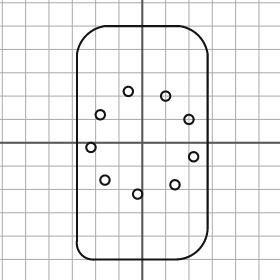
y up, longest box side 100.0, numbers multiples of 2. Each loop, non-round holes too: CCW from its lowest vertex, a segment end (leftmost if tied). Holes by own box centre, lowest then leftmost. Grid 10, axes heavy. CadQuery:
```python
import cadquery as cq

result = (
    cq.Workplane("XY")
    .moveTo(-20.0, -50.0)
    .lineTo(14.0, -50.0)
    .threePointArc((24.0, -46.0), (28.0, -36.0))
    .lineTo(28.0, 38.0)
    .threePointArc((24.0, 46.0), (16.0, 50.0))
    .lineTo(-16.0, 50.0)
    .threePointArc((-24.0, 46.0), (-28.0, 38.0))
    .lineTo(-28.0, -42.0)
    .threePointArc((-26.0, -48.0), (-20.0, -50.0))
    .close()
    .moveTo(-2.0, -22.0)
    .circle(2.0)
    .moveTo(14.0, -18.0)
    .circle(2.0)
    .moveTo(-16.0, -16.0)
    .circle(2.0)
    .moveTo(22.0, -6.0)
    .circle(2.0)
    .moveTo(-22.0, -2.0)
    .circle(2.0)
    .moveTo(20.0, 10.0)
    .circle(2.0)
    .moveTo(-18.0, 12.0)
    .circle(2.0)
    .moveTo(10.0, 20.0)
    .circle(2.0)
    .moveTo(-6.0, 22.0)
    .circle(2.0)
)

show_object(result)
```